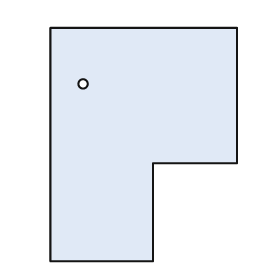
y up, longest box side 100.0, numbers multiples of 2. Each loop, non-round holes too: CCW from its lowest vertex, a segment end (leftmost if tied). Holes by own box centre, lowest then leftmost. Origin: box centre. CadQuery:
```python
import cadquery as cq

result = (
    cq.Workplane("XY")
    .moveTo(-40.0, -50.0)
    .lineTo(4.0, -50.0)
    .lineTo(4.0, -8.0)
    .lineTo(40.0, -8.0)
    .lineTo(40.0, 50.0)
    .lineTo(-40.0, 50.0)
    .close()
    .moveTo(-26.0, 26.0)
    .circle(2.0)
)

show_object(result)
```